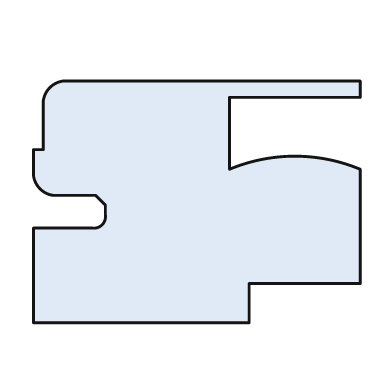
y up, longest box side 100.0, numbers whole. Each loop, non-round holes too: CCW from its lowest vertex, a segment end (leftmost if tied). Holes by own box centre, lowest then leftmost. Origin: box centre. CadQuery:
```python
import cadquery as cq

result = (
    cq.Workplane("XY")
    .moveTo(-50.0, -37.0)
    .lineTo(16.0, -37.0)
    .lineTo(16.0, -25.0)
    .lineTo(50.0, -25.0)
    .lineTo(50.0, 10.0)
    .threePointArc((30.0, 14.0), (10.0, 10.0))
    .lineTo(10.0, 32.0)
    .lineTo(50.0, 32.0)
    .lineTo(50.0, 37.0)
    .lineTo(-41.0, 37.0)
    .threePointArc((-45.0, 35.0), (-47.0, 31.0))
    .lineTo(-47.0, 16.0)
    .lineTo(-50.0, 16.0)
    .lineTo(-50.0, 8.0)
    .threePointArc((-48.0, 4.0), (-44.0, 2.0))
    .lineTo(-31.0, 2.0)
    .lineTo(-28.0, -1.0)
    .lineTo(-28.0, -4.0)
    .threePointArc((-29.0, -7.0), (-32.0, -8.0))
    .lineTo(-50.0, -8.0)
    .close()
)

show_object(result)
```